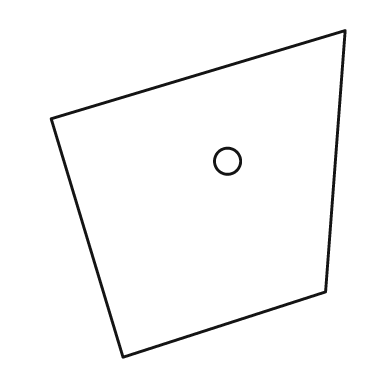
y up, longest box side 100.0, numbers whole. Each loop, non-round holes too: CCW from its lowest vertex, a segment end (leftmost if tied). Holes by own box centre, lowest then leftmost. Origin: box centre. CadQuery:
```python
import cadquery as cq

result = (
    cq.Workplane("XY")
    .moveTo(-23.0, -50.0)
    .lineTo(39.0, -30.0)
    .lineTo(45.0, 50.0)
    .lineTo(-45.0, 23.0)
    .close()
    .moveTo(9.0, 10.0)
    .circle(4.0)
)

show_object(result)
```